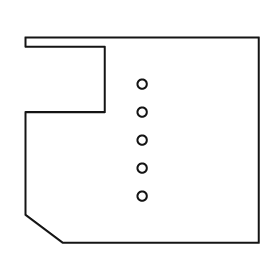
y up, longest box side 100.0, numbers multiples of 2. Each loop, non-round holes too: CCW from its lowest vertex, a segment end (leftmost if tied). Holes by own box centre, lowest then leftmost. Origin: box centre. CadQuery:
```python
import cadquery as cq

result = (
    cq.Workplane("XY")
    .moveTo(-34.0, -44.0)
    .lineTo(50.0, -44.0)
    .lineTo(50.0, 44.0)
    .lineTo(-50.0, 44.0)
    .lineTo(-50.0, 40.0)
    .lineTo(-16.0, 40.0)
    .lineTo(-16.0, 12.0)
    .lineTo(-50.0, 12.0)
    .lineTo(-50.0, -32.0)
    .close()
    .moveTo(0.0, -24.0)
    .circle(2.0)
    .moveTo(0.0, -12.0)
    .circle(2.0)
    .moveTo(0.0, 0.0)
    .circle(2.0)
    .moveTo(0.0, 12.0)
    .circle(2.0)
    .moveTo(0.0, 24.0)
    .circle(2.0)
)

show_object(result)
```